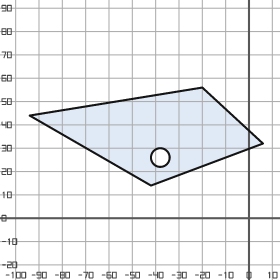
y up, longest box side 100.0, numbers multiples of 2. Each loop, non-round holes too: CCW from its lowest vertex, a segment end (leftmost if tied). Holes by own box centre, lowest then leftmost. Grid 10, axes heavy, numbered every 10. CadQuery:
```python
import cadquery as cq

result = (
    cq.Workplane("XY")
    .moveTo(-42.0, 14.0)
    .lineTo(6.0, 32.0)
    .lineTo(-20.0, 56.0)
    .lineTo(-94.0, 44.0)
    .close()
    .moveTo(-38.0, 26.0)
    .circle(4.0)
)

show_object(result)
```